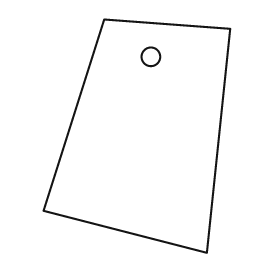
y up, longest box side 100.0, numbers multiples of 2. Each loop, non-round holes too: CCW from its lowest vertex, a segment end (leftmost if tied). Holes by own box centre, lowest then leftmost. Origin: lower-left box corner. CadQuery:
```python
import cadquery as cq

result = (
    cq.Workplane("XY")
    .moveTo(70.0, 0.0)
    .lineTo(80.0, 96.0)
    .lineTo(26.0, 100.0)
    .lineTo(0.0, 18.0)
    .close()
    .moveTo(46.0, 84.0)
    .circle(4.0)
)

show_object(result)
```